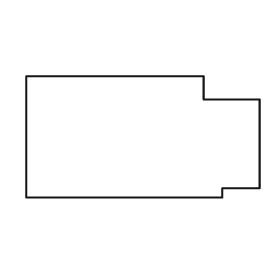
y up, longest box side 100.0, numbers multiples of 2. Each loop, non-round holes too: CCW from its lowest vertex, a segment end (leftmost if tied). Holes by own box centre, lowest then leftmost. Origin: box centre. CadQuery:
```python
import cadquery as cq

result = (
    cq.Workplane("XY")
    .moveTo(-50.0, -26.0)
    .lineTo(34.0, -26.0)
    .lineTo(34.0, -22.0)
    .lineTo(50.0, -22.0)
    .lineTo(50.0, 16.0)
    .lineTo(26.0, 16.0)
    .lineTo(26.0, 26.0)
    .lineTo(-50.0, 26.0)
    .close()
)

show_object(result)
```